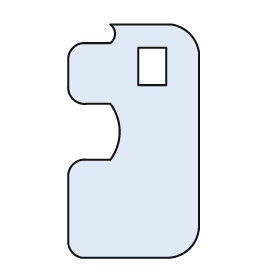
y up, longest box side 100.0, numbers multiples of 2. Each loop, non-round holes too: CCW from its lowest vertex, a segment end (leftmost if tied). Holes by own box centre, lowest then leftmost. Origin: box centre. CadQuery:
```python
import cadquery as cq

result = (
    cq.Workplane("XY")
    .moveTo(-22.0, -50.0)
    .lineTo(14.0, -50.0)
    .threePointArc((24.0, -46.0), (28.0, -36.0))
    .lineTo(28.0, 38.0)
    .threePointArc((24.0, 46.0), (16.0, 50.0))
    .lineTo(-10.0, 50.0)
    .threePointArc((-8.0, 46.0), (-10.0, 42.0))
    .lineTo(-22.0, 42.0)
    .threePointArc((-26.0, 40.0), (-28.0, 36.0))
    .lineTo(-28.0, 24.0)
    .threePointArc((-26.0, 18.0), (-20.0, 16.0))
    .lineTo(-10.0, 16.0)
    .threePointArc((-6.0, 4.0), (-10.0, -8.0))
    .lineTo(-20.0, -8.0)
    .threePointArc((-26.0, -10.0), (-28.0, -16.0))
    .lineTo(-28.0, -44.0)
    .threePointArc((-26.0, -48.0), (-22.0, -50.0))
    .close()
    .moveTo(2.0, 24.0)
    .lineTo(14.0, 24.0)
    .lineTo(14.0, 40.0)
    .lineTo(2.0, 40.0)
    .close()
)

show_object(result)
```